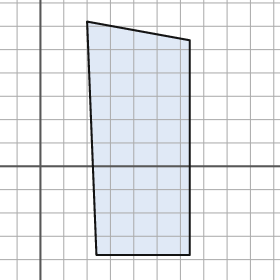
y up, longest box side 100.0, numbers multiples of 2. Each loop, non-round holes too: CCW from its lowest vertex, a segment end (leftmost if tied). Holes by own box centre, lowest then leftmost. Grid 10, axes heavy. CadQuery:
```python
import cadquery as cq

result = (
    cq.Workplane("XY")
    .moveTo(24.0, -38.0)
    .lineTo(64.0, -38.0)
    .lineTo(64.0, 54.0)
    .lineTo(20.0, 62.0)
    .close()
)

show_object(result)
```